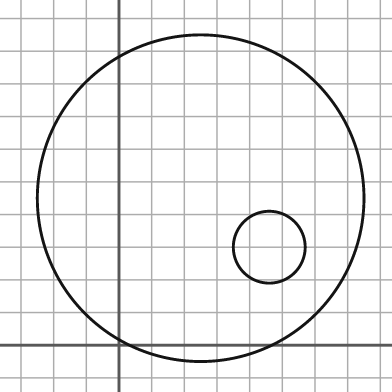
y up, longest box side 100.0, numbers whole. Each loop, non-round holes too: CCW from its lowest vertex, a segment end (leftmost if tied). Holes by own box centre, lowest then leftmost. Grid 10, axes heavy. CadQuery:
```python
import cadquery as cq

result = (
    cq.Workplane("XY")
    .moveTo(25.0, 45.0)
    .circle(50.0)
    .moveTo(46.0, 30.0)
    .circle(11.0)
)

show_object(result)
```